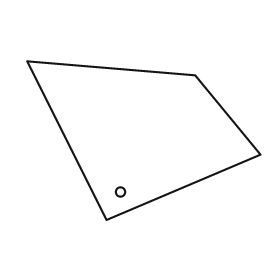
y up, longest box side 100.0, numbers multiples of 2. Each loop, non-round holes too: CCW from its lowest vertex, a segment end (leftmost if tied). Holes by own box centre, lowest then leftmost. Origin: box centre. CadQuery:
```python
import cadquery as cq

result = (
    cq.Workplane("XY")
    .moveTo(-16.0, -34.0)
    .lineTo(50.0, -6.0)
    .lineTo(22.0, 28.0)
    .lineTo(-50.0, 34.0)
    .close()
    .moveTo(-10.0, -22.0)
    .circle(2.0)
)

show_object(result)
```